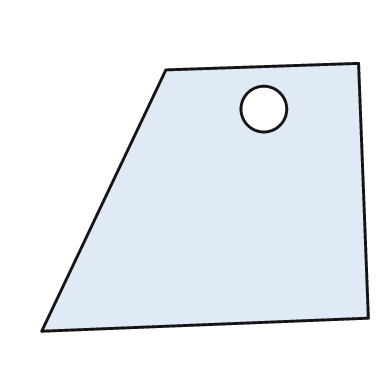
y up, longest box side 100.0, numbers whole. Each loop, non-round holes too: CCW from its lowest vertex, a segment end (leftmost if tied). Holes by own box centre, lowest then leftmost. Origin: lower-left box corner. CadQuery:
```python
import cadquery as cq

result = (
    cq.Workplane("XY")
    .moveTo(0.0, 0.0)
    .lineTo(100.0, 4.0)
    .lineTo(97.0, 82.0)
    .lineTo(38.0, 80.0)
    .close()
    .moveTo(68.0, 68.0)
    .circle(7.0)
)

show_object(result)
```